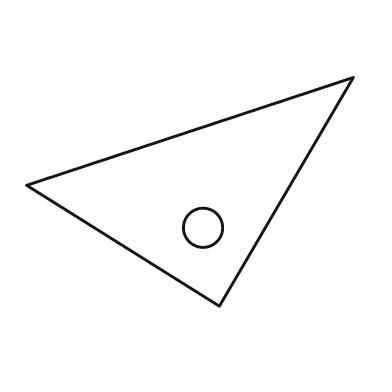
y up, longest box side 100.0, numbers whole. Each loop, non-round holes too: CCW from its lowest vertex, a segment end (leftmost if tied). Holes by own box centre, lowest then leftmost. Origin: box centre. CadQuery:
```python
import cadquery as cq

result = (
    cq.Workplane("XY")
    .moveTo(9.0, -35.0)
    .lineTo(50.0, 35.0)
    .lineTo(-50.0, 2.0)
    .close()
    .moveTo(4.0, -11.0)
    .circle(6.0)
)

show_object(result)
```